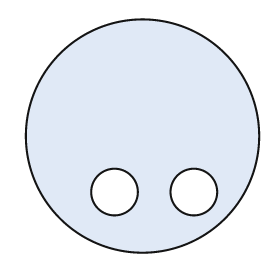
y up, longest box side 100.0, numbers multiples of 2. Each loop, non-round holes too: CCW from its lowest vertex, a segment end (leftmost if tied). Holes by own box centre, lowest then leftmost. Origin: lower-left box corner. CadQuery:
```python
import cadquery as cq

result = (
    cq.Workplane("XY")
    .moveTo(50.0, 50.0)
    .circle(50.0)
    .moveTo(38.0, 26.0)
    .circle(10.0)
    .moveTo(72.0, 26.0)
    .circle(10.0)
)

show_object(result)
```